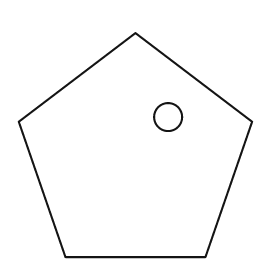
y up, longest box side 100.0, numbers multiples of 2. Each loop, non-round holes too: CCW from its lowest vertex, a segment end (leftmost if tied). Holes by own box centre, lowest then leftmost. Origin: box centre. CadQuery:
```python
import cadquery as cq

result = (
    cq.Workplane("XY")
    .moveTo(-30.0, -48.0)
    .lineTo(30.0, -48.0)
    .lineTo(50.0, 10.0)
    .lineTo(0.0, 48.0)
    .lineTo(-50.0, 10.0)
    .close()
    .moveTo(14.0, 12.0)
    .circle(6.0)
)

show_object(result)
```